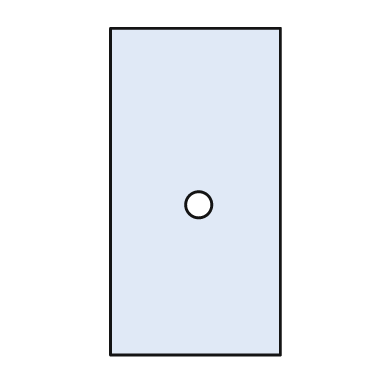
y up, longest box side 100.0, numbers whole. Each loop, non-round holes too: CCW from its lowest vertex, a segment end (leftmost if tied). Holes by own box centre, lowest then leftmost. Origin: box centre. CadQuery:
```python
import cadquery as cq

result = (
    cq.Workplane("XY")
    .moveTo(-26.0, -50.0)
    .lineTo(26.0, -50.0)
    .lineTo(26.0, 50.0)
    .lineTo(-26.0, 50.0)
    .close()
    .moveTo(1.0, -4.0)
    .circle(4.0)
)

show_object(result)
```